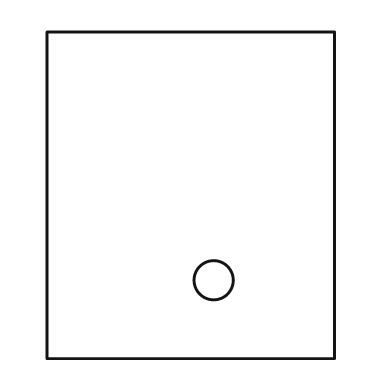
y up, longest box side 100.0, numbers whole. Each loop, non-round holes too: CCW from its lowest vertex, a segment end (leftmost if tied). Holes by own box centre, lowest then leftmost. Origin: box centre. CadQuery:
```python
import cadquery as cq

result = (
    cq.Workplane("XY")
    .moveTo(-44.0, -50.0)
    .lineTo(44.0, -50.0)
    .lineTo(44.0, 50.0)
    .lineTo(-44.0, 50.0)
    .close()
    .moveTo(7.0, -26.0)
    .circle(6.0)
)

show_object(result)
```